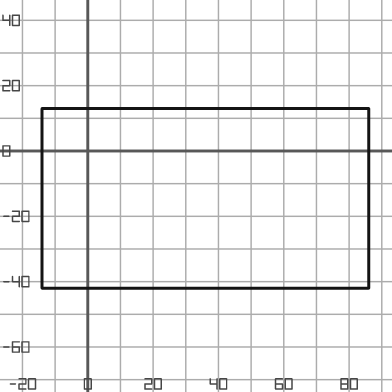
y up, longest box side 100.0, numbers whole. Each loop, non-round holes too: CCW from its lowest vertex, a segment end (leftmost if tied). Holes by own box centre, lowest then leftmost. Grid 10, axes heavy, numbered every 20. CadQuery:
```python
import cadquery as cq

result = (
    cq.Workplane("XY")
    .moveTo(-14.0, -42.0)
    .lineTo(86.0, -42.0)
    .lineTo(86.0, 13.0)
    .lineTo(-14.0, 13.0)
    .close()
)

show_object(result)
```